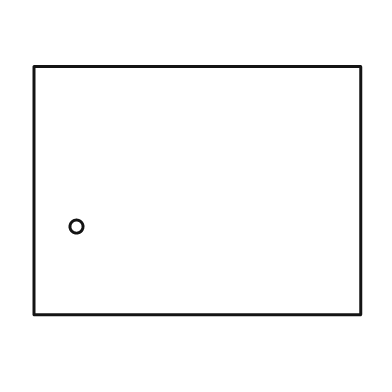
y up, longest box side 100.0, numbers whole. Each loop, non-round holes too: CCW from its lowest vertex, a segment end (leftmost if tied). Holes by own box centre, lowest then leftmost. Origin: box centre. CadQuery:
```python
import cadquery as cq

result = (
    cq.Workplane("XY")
    .moveTo(-50.0, -38.0)
    .lineTo(50.0, -38.0)
    .lineTo(50.0, 38.0)
    .lineTo(-50.0, 38.0)
    .close()
    .moveTo(-37.0, -11.0)
    .circle(2.0)
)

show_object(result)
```